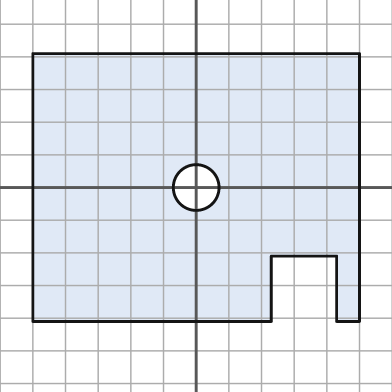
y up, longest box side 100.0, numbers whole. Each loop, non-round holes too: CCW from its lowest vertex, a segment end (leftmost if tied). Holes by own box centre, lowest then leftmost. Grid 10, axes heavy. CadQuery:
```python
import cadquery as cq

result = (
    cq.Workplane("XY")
    .moveTo(-50.0, -41.0)
    .lineTo(23.0, -41.0)
    .lineTo(23.0, -21.0)
    .lineTo(43.0, -21.0)
    .lineTo(43.0, -41.0)
    .lineTo(50.0, -41.0)
    .lineTo(50.0, 41.0)
    .lineTo(-50.0, 41.0)
    .close()
    .moveTo(0.0, 0.0)
    .circle(7.0)
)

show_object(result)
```